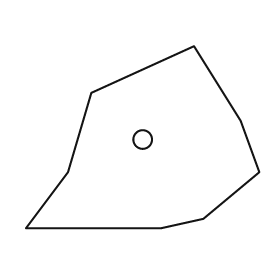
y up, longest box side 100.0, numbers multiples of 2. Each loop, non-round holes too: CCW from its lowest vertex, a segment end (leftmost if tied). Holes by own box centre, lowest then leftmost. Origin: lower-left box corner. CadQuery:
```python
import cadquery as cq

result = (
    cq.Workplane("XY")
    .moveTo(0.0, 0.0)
    .lineTo(58.0, 0.0)
    .lineTo(76.0, 4.0)
    .lineTo(100.0, 24.0)
    .lineTo(92.0, 46.0)
    .lineTo(72.0, 78.0)
    .lineTo(28.0, 58.0)
    .lineTo(18.0, 24.0)
    .close()
    .moveTo(50.0, 38.0)
    .circle(4.0)
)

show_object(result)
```